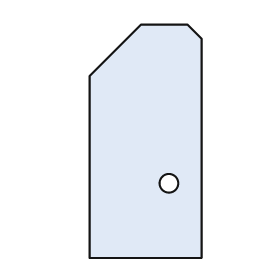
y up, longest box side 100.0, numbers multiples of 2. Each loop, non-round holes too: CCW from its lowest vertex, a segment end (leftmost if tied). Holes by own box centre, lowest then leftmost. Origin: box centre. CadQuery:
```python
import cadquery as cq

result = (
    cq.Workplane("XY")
    .moveTo(-24.0, -50.0)
    .lineTo(24.0, -50.0)
    .lineTo(24.0, 44.0)
    .lineTo(18.0, 50.0)
    .lineTo(-2.0, 50.0)
    .lineTo(-24.0, 28.0)
    .close()
    .moveTo(10.0, -18.0)
    .circle(4.0)
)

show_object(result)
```